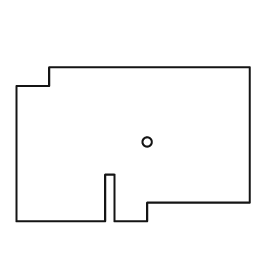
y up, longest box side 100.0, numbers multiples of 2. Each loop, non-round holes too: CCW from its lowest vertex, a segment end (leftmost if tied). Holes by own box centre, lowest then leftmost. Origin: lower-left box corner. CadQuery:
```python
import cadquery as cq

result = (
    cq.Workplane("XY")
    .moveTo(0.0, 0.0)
    .lineTo(38.0, 0.0)
    .lineTo(38.0, 20.0)
    .lineTo(42.0, 20.0)
    .lineTo(42.0, 0.0)
    .lineTo(56.0, 0.0)
    .lineTo(56.0, 8.0)
    .lineTo(100.0, 8.0)
    .lineTo(100.0, 66.0)
    .lineTo(14.0, 66.0)
    .lineTo(14.0, 58.0)
    .lineTo(0.0, 58.0)
    .close()
    .moveTo(56.0, 34.0)
    .circle(2.0)
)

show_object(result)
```